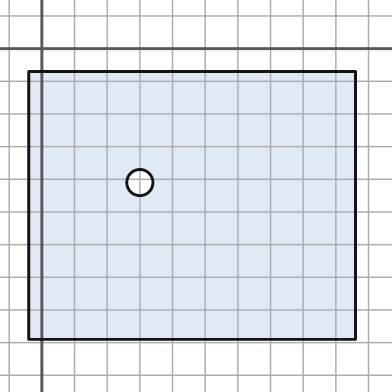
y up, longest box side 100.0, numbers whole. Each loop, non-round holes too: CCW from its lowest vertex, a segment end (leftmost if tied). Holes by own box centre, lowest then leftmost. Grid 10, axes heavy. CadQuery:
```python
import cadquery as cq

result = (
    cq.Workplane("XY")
    .moveTo(-4.0, -89.0)
    .lineTo(96.0, -89.0)
    .lineTo(96.0, -7.0)
    .lineTo(-4.0, -7.0)
    .close()
    .moveTo(30.0, -41.0)
    .circle(4.0)
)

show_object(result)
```